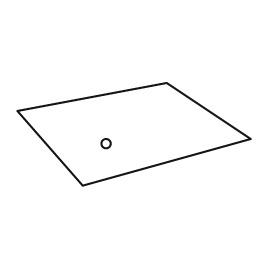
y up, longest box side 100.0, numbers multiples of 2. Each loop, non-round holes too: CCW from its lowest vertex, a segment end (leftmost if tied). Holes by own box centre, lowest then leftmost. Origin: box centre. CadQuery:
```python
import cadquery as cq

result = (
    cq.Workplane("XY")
    .moveTo(-22.0, -22.0)
    .lineTo(50.0, -2.0)
    .lineTo(14.0, 22.0)
    .lineTo(-50.0, 10.0)
    .close()
    .moveTo(-12.0, -4.0)
    .circle(2.0)
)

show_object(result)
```